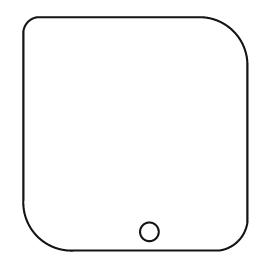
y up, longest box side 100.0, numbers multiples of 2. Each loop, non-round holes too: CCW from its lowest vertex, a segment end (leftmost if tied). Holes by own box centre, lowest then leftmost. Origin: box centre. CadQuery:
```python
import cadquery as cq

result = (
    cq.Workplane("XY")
    .moveTo(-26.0, -50.0)
    .lineTo(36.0, -50.0)
    .threePointArc((44.0, -46.0), (48.0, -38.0))
    .lineTo(48.0, 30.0)
    .threePointArc((42.0, 44.0), (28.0, 50.0))
    .lineTo(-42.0, 50.0)
    .threePointArc((-46.0, 48.0), (-48.0, 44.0))
    .lineTo(-48.0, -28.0)
    .threePointArc((-42.0, -44.0), (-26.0, -50.0))
    .close()
    .moveTo(6.0, -42.0)
    .circle(4.0)
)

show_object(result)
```